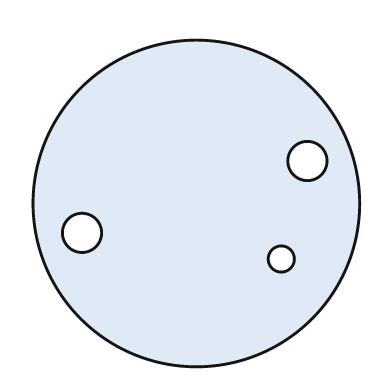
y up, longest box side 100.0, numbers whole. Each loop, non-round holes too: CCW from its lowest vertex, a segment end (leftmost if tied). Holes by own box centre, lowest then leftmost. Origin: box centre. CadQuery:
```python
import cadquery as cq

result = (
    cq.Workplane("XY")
    .moveTo(0.0, 0.0)
    .circle(50.0)
    .moveTo(26.0, -17.0)
    .circle(4.0)
    .moveTo(-35.0, -9.0)
    .circle(6.0)
    .moveTo(34.0, 13.0)
    .circle(6.0)
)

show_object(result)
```